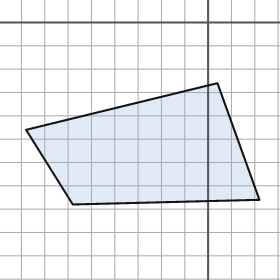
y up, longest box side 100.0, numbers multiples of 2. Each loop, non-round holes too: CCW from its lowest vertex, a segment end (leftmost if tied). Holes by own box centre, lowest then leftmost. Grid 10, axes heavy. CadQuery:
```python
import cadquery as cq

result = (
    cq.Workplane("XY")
    .moveTo(-58.0, -78.0)
    .lineTo(22.0, -76.0)
    .lineTo(4.0, -26.0)
    .lineTo(-78.0, -46.0)
    .close()
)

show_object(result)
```